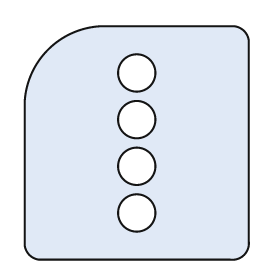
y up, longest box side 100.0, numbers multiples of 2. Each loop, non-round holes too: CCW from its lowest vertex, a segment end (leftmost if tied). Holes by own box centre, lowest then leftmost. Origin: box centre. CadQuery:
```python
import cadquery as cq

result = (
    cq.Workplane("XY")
    .moveTo(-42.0, -50.0)
    .lineTo(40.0, -50.0)
    .threePointArc((46.0, -48.0), (48.0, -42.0))
    .lineTo(48.0, 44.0)
    .threePointArc((46.0, 48.0), (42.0, 50.0))
    .lineTo(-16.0, 50.0)
    .threePointArc((-38.0, 40.0), (-48.0, 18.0))
    .lineTo(-48.0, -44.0)
    .threePointArc((-46.0, -48.0), (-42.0, -50.0))
    .close()
    .moveTo(0.0, -30.0)
    .circle(8.0)
    .moveTo(0.0, -10.0)
    .circle(8.0)
    .moveTo(0.0, 10.0)
    .circle(8.0)
    .moveTo(0.0, 30.0)
    .circle(8.0)
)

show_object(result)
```